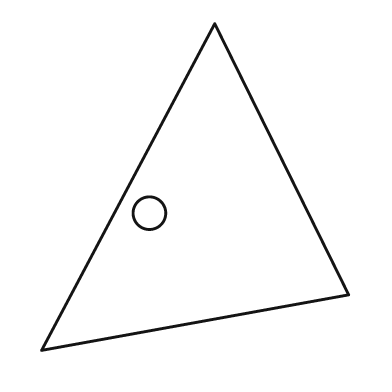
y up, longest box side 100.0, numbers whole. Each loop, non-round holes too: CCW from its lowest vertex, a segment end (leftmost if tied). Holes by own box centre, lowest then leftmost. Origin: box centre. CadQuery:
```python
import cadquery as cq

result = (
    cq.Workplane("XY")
    .moveTo(-47.0, -50.0)
    .lineTo(47.0, -33.0)
    .lineTo(6.0, 50.0)
    .close()
    .moveTo(-14.0, -8.0)
    .circle(5.0)
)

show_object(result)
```